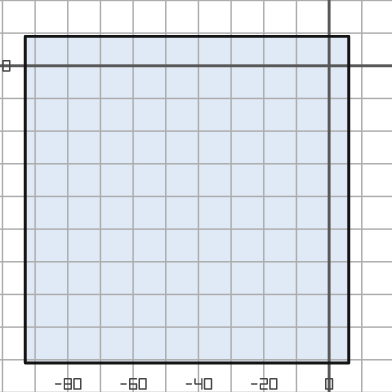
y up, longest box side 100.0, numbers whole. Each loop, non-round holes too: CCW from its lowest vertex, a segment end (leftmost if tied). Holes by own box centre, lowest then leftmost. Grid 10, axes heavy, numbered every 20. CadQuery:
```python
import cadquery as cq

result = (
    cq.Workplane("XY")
    .moveTo(-93.0, -91.0)
    .lineTo(6.0, -91.0)
    .lineTo(6.0, 9.0)
    .lineTo(-93.0, 9.0)
    .close()
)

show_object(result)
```